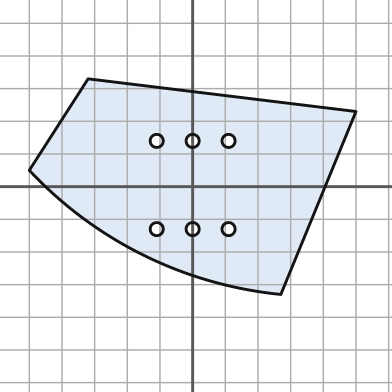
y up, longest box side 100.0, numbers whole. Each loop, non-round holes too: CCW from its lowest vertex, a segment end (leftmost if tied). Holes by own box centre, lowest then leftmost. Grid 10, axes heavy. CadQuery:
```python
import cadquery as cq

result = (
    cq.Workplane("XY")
    .moveTo(27.0, -33.0)
    .lineTo(50.0, 23.0)
    .lineTo(-32.0, 33.0)
    .lineTo(-50.0, 5.0)
    .threePointArc((-15.0, -21.0), (27.0, -33.0))
    .close()
    .moveTo(-11.0, -13.0)
    .circle(2.0)
    .moveTo(0.0, -13.0)
    .circle(2.0)
    .moveTo(11.0, -13.0)
    .circle(2.0)
    .moveTo(-11.0, 14.0)
    .circle(2.0)
    .moveTo(0.0, 14.0)
    .circle(2.0)
    .moveTo(11.0, 14.0)
    .circle(2.0)
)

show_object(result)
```